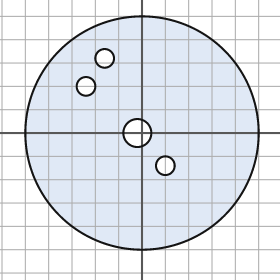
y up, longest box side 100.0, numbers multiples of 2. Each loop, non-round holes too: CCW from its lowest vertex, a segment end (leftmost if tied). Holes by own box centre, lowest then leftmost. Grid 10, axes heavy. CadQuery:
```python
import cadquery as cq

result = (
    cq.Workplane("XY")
    .moveTo(0.0, 0.0)
    .circle(50.0)
    .moveTo(10.0, -14.0)
    .circle(4.0)
    .moveTo(-2.0, 0.0)
    .circle(6.0)
    .moveTo(-24.0, 20.0)
    .circle(4.0)
    .moveTo(-16.0, 32.0)
    .circle(4.0)
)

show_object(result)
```